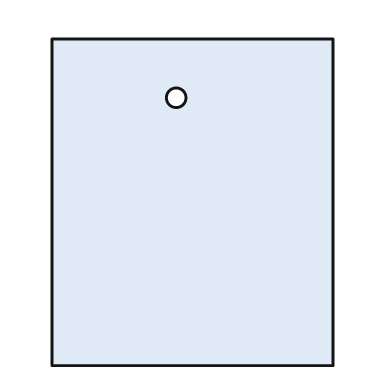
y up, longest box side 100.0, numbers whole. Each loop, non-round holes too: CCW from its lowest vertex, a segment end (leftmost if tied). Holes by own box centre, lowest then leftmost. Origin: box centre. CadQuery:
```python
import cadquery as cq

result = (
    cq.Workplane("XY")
    .moveTo(-43.0, -50.0)
    .lineTo(43.0, -50.0)
    .lineTo(43.0, 50.0)
    .lineTo(-43.0, 50.0)
    .close()
    .moveTo(-5.0, 32.0)
    .circle(3.0)
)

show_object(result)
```